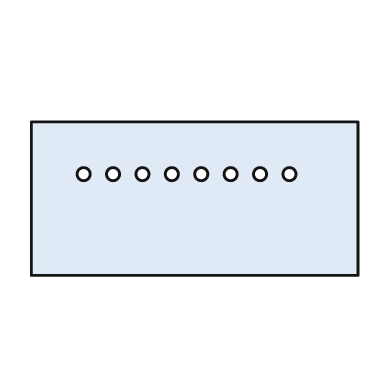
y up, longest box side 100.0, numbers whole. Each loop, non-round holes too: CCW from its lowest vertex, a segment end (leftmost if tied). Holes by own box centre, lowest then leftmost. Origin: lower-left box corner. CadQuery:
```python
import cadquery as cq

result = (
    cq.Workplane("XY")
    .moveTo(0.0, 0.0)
    .lineTo(100.0, 0.0)
    .lineTo(100.0, 47.0)
    .lineTo(0.0, 47.0)
    .close()
    .moveTo(16.0, 31.0)
    .circle(2.0)
    .moveTo(25.0, 31.0)
    .circle(2.0)
    .moveTo(34.0, 31.0)
    .circle(2.0)
    .moveTo(43.0, 31.0)
    .circle(2.0)
    .moveTo(52.0, 31.0)
    .circle(2.0)
    .moveTo(61.0, 31.0)
    .circle(2.0)
    .moveTo(70.0, 31.0)
    .circle(2.0)
    .moveTo(79.0, 31.0)
    .circle(2.0)
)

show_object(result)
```